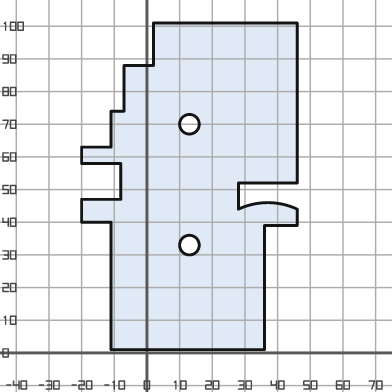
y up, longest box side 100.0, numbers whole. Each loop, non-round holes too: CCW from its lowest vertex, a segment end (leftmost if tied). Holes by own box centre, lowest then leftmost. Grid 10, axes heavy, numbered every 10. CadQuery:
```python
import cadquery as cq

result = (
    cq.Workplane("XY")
    .moveTo(-11.0, 1.0)
    .lineTo(36.0, 1.0)
    .lineTo(36.0, 39.0)
    .lineTo(46.0, 39.0)
    .lineTo(46.0, 44.0)
    .threePointArc((37.0, 46.0), (28.0, 44.0))
    .lineTo(28.0, 52.0)
    .lineTo(46.0, 52.0)
    .lineTo(46.0, 101.0)
    .lineTo(2.0, 101.0)
    .lineTo(2.0, 88.0)
    .lineTo(-7.0, 88.0)
    .lineTo(-7.0, 74.0)
    .lineTo(-11.0, 74.0)
    .lineTo(-11.0, 63.0)
    .lineTo(-20.0, 63.0)
    .lineTo(-20.0, 58.0)
    .lineTo(-8.0, 58.0)
    .lineTo(-8.0, 47.0)
    .lineTo(-20.0, 47.0)
    .lineTo(-20.0, 40.0)
    .lineTo(-11.0, 40.0)
    .close()
    .moveTo(13.0, 33.0)
    .circle(3.0)
    .moveTo(13.0, 70.0)
    .circle(3.0)
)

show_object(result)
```